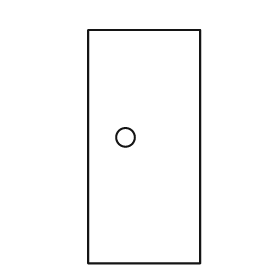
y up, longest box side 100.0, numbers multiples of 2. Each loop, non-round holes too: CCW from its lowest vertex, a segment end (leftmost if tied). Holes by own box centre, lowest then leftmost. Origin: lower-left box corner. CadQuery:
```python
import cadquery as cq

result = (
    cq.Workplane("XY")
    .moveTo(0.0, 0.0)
    .lineTo(48.0, 0.0)
    .lineTo(48.0, 100.0)
    .lineTo(0.0, 100.0)
    .close()
    .moveTo(16.0, 54.0)
    .circle(4.0)
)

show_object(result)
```